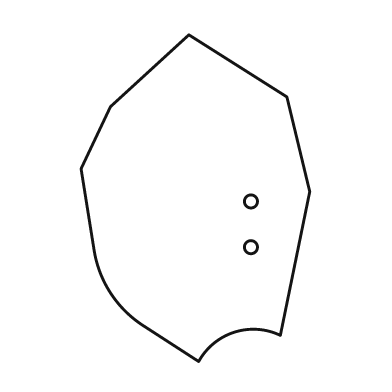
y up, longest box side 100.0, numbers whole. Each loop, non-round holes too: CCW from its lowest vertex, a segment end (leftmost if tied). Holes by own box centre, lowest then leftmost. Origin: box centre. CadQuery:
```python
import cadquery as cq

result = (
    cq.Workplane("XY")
    .moveTo(1.0, -50.0)
    .threePointArc((12.0, -41.0), (26.0, -42.0))
    .lineTo(35.0, 2.0)
    .lineTo(28.0, 31.0)
    .lineTo(-2.0, 50.0)
    .lineTo(-26.0, 28.0)
    .lineTo(-35.0, 9.0)
    .lineTo(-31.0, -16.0)
    .threePointArc((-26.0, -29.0), (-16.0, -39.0))
    .close()
    .moveTo(17.0, -15.0)
    .circle(2.0)
    .moveTo(17.0, -1.0)
    .circle(2.0)
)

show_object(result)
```